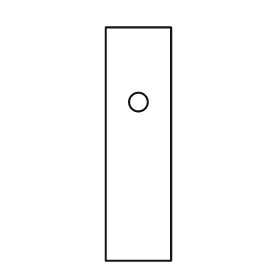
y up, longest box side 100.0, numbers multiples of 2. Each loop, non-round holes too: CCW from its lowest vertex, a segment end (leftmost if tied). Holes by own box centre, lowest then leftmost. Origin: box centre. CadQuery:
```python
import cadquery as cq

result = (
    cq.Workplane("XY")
    .moveTo(-14.0, -50.0)
    .lineTo(14.0, -50.0)
    .lineTo(14.0, 50.0)
    .lineTo(-14.0, 50.0)
    .close()
    .moveTo(0.0, 18.0)
    .circle(4.0)
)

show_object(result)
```